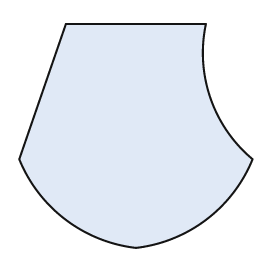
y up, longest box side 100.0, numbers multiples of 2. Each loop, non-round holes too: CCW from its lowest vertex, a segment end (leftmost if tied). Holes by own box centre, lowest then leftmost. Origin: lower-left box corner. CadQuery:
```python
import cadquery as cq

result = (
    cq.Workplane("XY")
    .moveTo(50.0, 0.0)
    .threePointArc((80.0, 12.0), (100.0, 38.0))
    .threePointArc((82.0, 64.0), (80.0, 96.0))
    .lineTo(20.0, 96.0)
    .lineTo(0.0, 38.0)
    .threePointArc((20.0, 12.0), (50.0, 0.0))
    .close()
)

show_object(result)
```